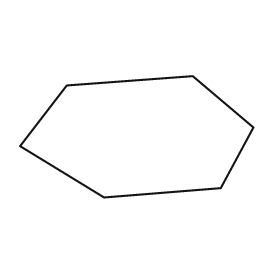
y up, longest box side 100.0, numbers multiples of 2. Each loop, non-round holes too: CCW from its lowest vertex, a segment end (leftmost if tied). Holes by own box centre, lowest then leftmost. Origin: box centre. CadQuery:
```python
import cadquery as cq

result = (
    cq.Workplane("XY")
    .moveTo(-14.0, -26.0)
    .lineTo(36.0, -22.0)
    .lineTo(50.0, 4.0)
    .lineTo(24.0, 26.0)
    .lineTo(-30.0, 22.0)
    .lineTo(-50.0, -4.0)
    .close()
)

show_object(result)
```